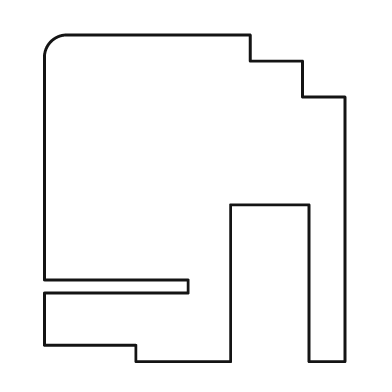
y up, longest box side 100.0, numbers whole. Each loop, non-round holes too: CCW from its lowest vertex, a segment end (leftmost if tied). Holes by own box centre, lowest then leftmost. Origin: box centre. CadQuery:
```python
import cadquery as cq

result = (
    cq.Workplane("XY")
    .moveTo(-18.0, -50.0)
    .lineTo(11.0, -50.0)
    .lineTo(11.0, -2.0)
    .lineTo(35.0, -2.0)
    .lineTo(35.0, -50.0)
    .lineTo(46.0, -50.0)
    .lineTo(46.0, 31.0)
    .lineTo(33.0, 31.0)
    .lineTo(33.0, 42.0)
    .lineTo(17.0, 42.0)
    .lineTo(17.0, 50.0)
    .lineTo(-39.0, 50.0)
    .threePointArc((-44.0, 48.0), (-46.0, 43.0))
    .lineTo(-46.0, -25.0)
    .lineTo(-2.0, -25.0)
    .lineTo(-2.0, -29.0)
    .lineTo(-46.0, -29.0)
    .lineTo(-46.0, -45.0)
    .lineTo(-18.0, -45.0)
    .close()
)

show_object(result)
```